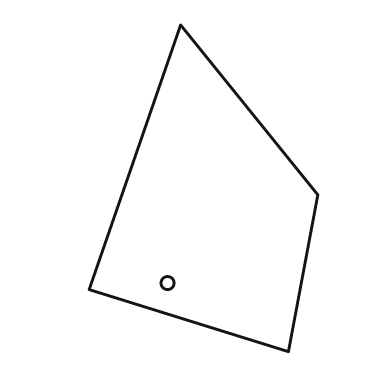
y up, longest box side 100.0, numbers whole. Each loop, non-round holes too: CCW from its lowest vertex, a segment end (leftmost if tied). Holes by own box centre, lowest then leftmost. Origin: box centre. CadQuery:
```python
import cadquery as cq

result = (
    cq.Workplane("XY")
    .moveTo(26.0, -50.0)
    .lineTo(35.0, -2.0)
    .lineTo(-7.0, 50.0)
    .lineTo(-35.0, -31.0)
    .close()
    .moveTo(-11.0, -29.0)
    .circle(2.0)
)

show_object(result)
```